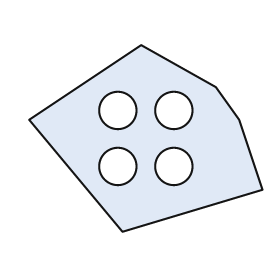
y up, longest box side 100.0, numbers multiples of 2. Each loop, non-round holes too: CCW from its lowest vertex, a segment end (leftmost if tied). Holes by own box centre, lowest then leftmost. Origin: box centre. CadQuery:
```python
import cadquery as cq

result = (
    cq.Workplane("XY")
    .moveTo(-10.0, -40.0)
    .lineTo(50.0, -22.0)
    .lineTo(40.0, 8.0)
    .lineTo(30.0, 22.0)
    .lineTo(-2.0, 40.0)
    .lineTo(-50.0, 8.0)
    .close()
    .moveTo(-12.0, -12.0)
    .circle(8.0)
    .moveTo(12.0, -12.0)
    .circle(8.0)
    .moveTo(-12.0, 12.0)
    .circle(8.0)
    .moveTo(12.0, 12.0)
    .circle(8.0)
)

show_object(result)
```